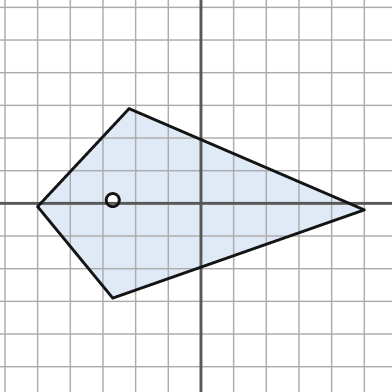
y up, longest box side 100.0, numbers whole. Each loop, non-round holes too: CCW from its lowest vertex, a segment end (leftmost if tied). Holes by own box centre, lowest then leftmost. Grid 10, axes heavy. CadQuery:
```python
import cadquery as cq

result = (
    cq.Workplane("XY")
    .moveTo(-27.0, -29.0)
    .lineTo(50.0, -2.0)
    .lineTo(-22.0, 29.0)
    .lineTo(-50.0, -1.0)
    .close()
    .moveTo(-27.0, 1.0)
    .circle(2.0)
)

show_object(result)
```